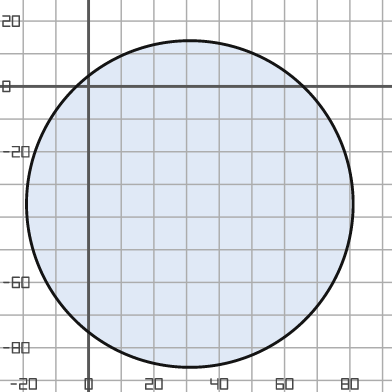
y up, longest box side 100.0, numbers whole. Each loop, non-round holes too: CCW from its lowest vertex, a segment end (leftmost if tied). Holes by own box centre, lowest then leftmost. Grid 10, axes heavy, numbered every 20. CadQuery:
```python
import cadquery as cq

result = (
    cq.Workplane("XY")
    .moveTo(31.0, -36.0)
    .circle(50.0)
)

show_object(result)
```